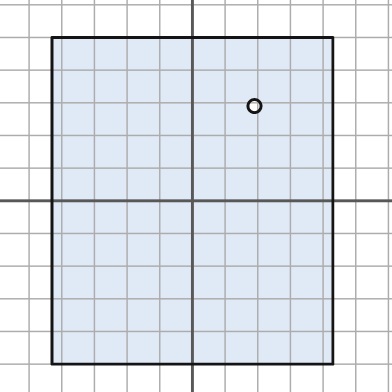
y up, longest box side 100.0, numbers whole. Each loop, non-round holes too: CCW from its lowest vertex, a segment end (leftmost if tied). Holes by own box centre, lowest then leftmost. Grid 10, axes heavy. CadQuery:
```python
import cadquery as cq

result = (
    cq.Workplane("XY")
    .moveTo(-43.0, -50.0)
    .lineTo(43.0, -50.0)
    .lineTo(43.0, 50.0)
    .lineTo(-43.0, 50.0)
    .close()
    .moveTo(19.0, 29.0)
    .circle(2.0)
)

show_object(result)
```